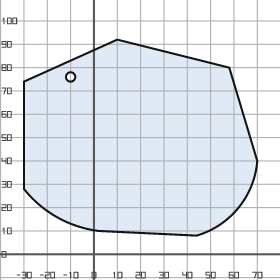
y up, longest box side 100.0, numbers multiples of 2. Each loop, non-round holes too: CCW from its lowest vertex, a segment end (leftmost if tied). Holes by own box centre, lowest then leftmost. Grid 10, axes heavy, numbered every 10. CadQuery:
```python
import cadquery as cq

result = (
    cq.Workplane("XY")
    .moveTo(44.0, 8.0)
    .threePointArc((62.0, 20.0), (70.0, 40.0))
    .lineTo(58.0, 80.0)
    .lineTo(10.0, 92.0)
    .lineTo(-30.0, 74.0)
    .lineTo(-30.0, 28.0)
    .threePointArc((-16.0, 16.0), (2.0, 10.0))
    .close()
    .moveTo(-10.0, 76.0)
    .circle(2.0)
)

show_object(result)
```